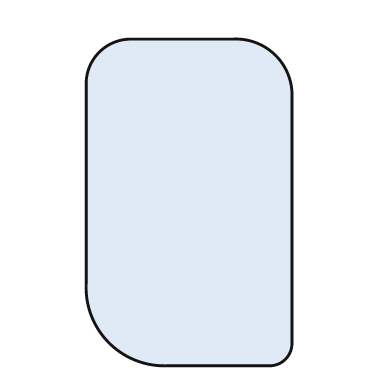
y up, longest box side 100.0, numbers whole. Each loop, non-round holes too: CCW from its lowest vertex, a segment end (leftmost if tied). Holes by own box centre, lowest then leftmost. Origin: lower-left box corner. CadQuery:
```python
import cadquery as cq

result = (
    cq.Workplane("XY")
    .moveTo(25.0, 0.0)
    .lineTo(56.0, 0.0)
    .threePointArc((61.0, 2.0), (63.0, 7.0))
    .lineTo(63.0, 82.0)
    .threePointArc((58.0, 95.0), (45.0, 100.0))
    .lineTo(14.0, 100.0)
    .threePointArc((4.0, 96.0), (0.0, 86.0))
    .lineTo(0.0, 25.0)
    .threePointArc((7.0, 7.0), (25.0, 0.0))
    .close()
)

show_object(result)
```